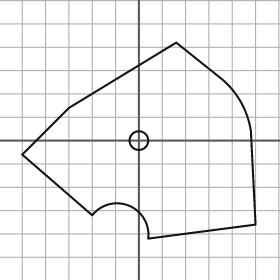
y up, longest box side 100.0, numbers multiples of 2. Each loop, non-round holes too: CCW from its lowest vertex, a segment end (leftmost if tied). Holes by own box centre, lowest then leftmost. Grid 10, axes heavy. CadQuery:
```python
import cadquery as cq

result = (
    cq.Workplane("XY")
    .moveTo(4.0, -42.0)
    .lineTo(50.0, -36.0)
    .lineTo(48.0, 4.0)
    .threePointArc((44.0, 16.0), (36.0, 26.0))
    .lineTo(16.0, 42.0)
    .lineTo(-30.0, 14.0)
    .lineTo(-50.0, -6.0)
    .lineTo(-20.0, -32.0)
    .threePointArc((-4.0, -28.0), (4.0, -42.0))
    .close()
    .moveTo(0.0, 0.0)
    .circle(4.0)
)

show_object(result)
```